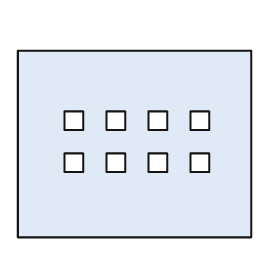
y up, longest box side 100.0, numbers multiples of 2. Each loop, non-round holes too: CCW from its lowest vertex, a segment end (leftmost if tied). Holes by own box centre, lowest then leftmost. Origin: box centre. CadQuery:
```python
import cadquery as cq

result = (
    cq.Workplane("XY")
    .moveTo(-50.0, -40.0)
    .lineTo(50.0, -40.0)
    .lineTo(50.0, 40.0)
    .lineTo(-50.0, 40.0)
    .close()
    .moveTo(-30.0, -12.0)
    .lineTo(-22.0, -12.0)
    .lineTo(-22.0, -4.0)
    .lineTo(-30.0, -4.0)
    .close()
    .moveTo(-12.0, -12.0)
    .lineTo(-4.0, -12.0)
    .lineTo(-4.0, -4.0)
    .lineTo(-12.0, -4.0)
    .close()
    .moveTo(6.0, -12.0)
    .lineTo(14.0, -12.0)
    .lineTo(14.0, -4.0)
    .lineTo(6.0, -4.0)
    .close()
    .moveTo(24.0, -12.0)
    .lineTo(32.0, -12.0)
    .lineTo(32.0, -4.0)
    .lineTo(24.0, -4.0)
    .close()
    .moveTo(-30.0, 6.0)
    .lineTo(-22.0, 6.0)
    .lineTo(-22.0, 14.0)
    .lineTo(-30.0, 14.0)
    .close()
    .moveTo(-12.0, 6.0)
    .lineTo(-4.0, 6.0)
    .lineTo(-4.0, 14.0)
    .lineTo(-12.0, 14.0)
    .close()
    .moveTo(6.0, 6.0)
    .lineTo(14.0, 6.0)
    .lineTo(14.0, 14.0)
    .lineTo(6.0, 14.0)
    .close()
    .moveTo(24.0, 6.0)
    .lineTo(32.0, 6.0)
    .lineTo(32.0, 14.0)
    .lineTo(24.0, 14.0)
    .close()
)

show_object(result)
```